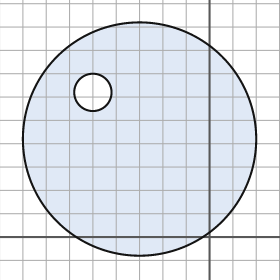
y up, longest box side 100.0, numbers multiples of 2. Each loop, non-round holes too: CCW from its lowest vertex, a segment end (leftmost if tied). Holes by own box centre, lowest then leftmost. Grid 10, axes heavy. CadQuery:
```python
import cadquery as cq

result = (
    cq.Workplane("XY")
    .moveTo(-30.0, 42.0)
    .circle(50.0)
    .moveTo(-50.0, 62.0)
    .circle(8.0)
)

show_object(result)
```